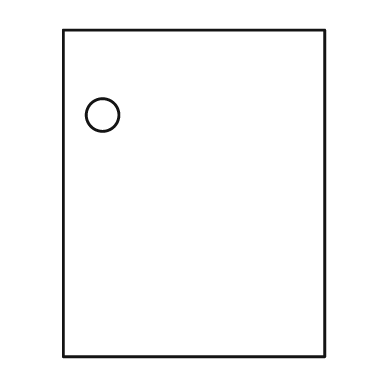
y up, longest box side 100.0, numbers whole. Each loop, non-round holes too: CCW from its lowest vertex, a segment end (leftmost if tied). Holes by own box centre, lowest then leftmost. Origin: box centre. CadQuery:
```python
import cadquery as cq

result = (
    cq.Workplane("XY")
    .moveTo(-40.0, -50.0)
    .lineTo(40.0, -50.0)
    .lineTo(40.0, 50.0)
    .lineTo(-40.0, 50.0)
    .close()
    .moveTo(-28.0, 24.0)
    .circle(5.0)
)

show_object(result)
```